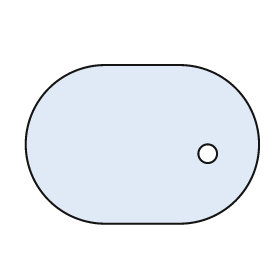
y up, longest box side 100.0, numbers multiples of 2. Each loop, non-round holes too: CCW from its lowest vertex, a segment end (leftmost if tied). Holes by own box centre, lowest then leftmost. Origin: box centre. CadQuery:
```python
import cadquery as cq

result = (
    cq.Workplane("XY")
    .moveTo(-16.0, -34.0)
    .lineTo(16.0, -34.0)
    .threePointArc((50.0, 0.0), (16.0, 34.0))
    .lineTo(-16.0, 34.0)
    .threePointArc((-50.0, 0.0), (-16.0, -34.0))
    .close()
    .moveTo(28.0, -4.0)
    .circle(4.0)
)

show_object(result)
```